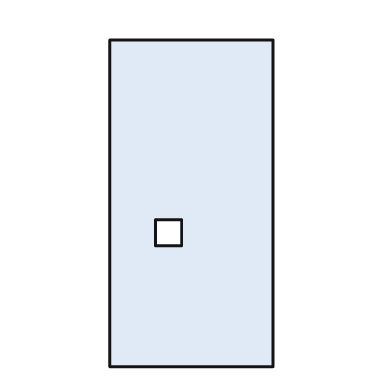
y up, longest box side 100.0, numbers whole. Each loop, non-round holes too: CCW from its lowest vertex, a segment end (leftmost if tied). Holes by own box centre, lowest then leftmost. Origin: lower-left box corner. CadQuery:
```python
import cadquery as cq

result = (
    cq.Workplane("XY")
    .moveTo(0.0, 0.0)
    .lineTo(50.0, 0.0)
    .lineTo(50.0, 100.0)
    .lineTo(0.0, 100.0)
    .close()
    .moveTo(14.0, 37.0)
    .lineTo(22.0, 37.0)
    .lineTo(22.0, 45.0)
    .lineTo(14.0, 45.0)
    .close()
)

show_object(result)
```